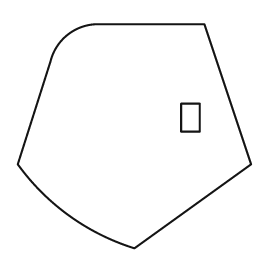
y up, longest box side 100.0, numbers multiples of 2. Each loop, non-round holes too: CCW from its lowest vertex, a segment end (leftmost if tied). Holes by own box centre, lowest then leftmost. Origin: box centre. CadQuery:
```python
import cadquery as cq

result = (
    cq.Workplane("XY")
    .moveTo(0.0, -48.0)
    .lineTo(50.0, -12.0)
    .lineTo(30.0, 48.0)
    .lineTo(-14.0, 48.0)
    .threePointArc((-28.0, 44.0), (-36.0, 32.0))
    .lineTo(-50.0, -12.0)
    .threePointArc((-28.0, -34.0), (0.0, -48.0))
    .close()
    .moveTo(20.0, 2.0)
    .lineTo(28.0, 2.0)
    .lineTo(28.0, 14.0)
    .lineTo(20.0, 14.0)
    .close()
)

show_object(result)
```